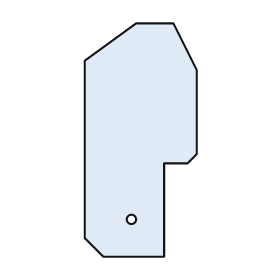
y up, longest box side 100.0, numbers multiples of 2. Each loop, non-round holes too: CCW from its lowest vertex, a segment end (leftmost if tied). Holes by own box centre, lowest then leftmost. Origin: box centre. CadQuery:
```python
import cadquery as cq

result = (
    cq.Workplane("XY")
    .moveTo(-16.0, -50.0)
    .lineTo(10.0, -50.0)
    .lineTo(10.0, -10.0)
    .lineTo(20.0, -10.0)
    .lineTo(24.0, -6.0)
    .lineTo(24.0, 30.0)
    .lineTo(14.0, 50.0)
    .lineTo(-2.0, 50.0)
    .lineTo(-24.0, 34.0)
    .lineTo(-24.0, -42.0)
    .close()
    .moveTo(-4.0, -34.0)
    .circle(2.0)
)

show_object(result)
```